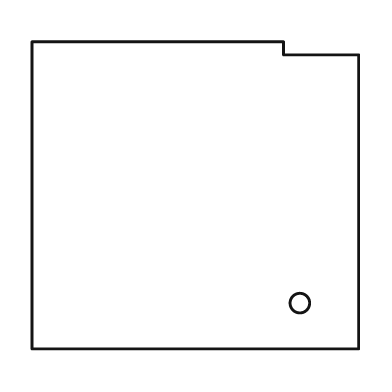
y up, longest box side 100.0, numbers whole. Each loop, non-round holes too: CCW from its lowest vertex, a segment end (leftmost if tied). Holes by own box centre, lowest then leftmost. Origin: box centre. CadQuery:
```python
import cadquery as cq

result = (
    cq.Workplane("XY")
    .moveTo(-50.0, -47.0)
    .lineTo(50.0, -47.0)
    .lineTo(50.0, 43.0)
    .lineTo(27.0, 43.0)
    .lineTo(27.0, 47.0)
    .lineTo(-50.0, 47.0)
    .close()
    .moveTo(32.0, -33.0)
    .circle(3.0)
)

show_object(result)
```